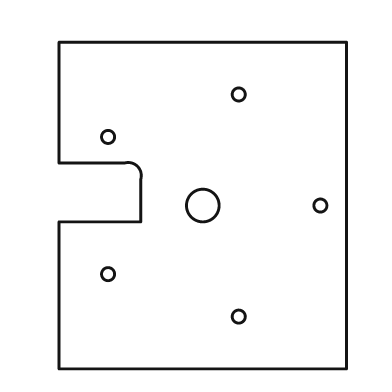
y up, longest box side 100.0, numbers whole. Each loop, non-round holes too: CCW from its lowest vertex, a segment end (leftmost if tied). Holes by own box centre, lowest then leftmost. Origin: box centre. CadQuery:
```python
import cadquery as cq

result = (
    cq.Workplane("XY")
    .moveTo(-44.0, -50.0)
    .lineTo(44.0, -50.0)
    .lineTo(44.0, 50.0)
    .lineTo(-44.0, 50.0)
    .lineTo(-44.0, 13.0)
    .lineTo(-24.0, 13.0)
    .threePointArc((-20.0, 12.0), (-19.0, 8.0))
    .lineTo(-19.0, -5.0)
    .lineTo(-44.0, -5.0)
    .close()
    .moveTo(11.0, -34.0)
    .circle(2.0)
    .moveTo(-29.0, -21.0)
    .circle(2.0)
    .moveTo(0.0, 0.0)
    .circle(5.0)
    .moveTo(36.0, 0.0)
    .circle(2.0)
    .moveTo(-29.0, 21.0)
    .circle(2.0)
    .moveTo(11.0, 34.0)
    .circle(2.0)
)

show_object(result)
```